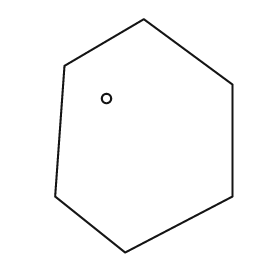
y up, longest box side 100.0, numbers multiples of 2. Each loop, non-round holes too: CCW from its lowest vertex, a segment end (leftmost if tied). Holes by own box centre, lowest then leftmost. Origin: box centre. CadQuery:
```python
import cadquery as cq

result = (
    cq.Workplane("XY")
    .moveTo(-8.0, -50.0)
    .lineTo(38.0, -26.0)
    .lineTo(38.0, 22.0)
    .lineTo(0.0, 50.0)
    .lineTo(-34.0, 30.0)
    .lineTo(-38.0, -26.0)
    .close()
    .moveTo(-16.0, 16.0)
    .circle(2.0)
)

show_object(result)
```